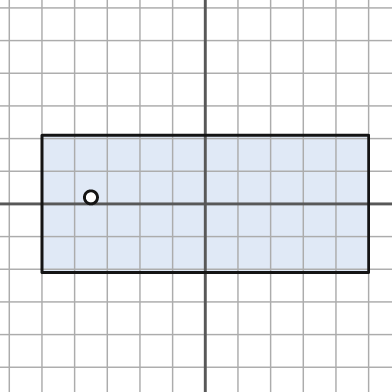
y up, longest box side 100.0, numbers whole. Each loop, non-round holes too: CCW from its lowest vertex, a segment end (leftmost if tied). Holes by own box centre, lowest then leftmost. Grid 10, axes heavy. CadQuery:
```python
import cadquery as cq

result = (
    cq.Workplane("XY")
    .moveTo(-50.0, -21.0)
    .lineTo(50.0, -21.0)
    .lineTo(50.0, 21.0)
    .lineTo(-50.0, 21.0)
    .close()
    .moveTo(-35.0, 2.0)
    .circle(2.0)
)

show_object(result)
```